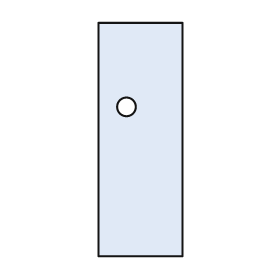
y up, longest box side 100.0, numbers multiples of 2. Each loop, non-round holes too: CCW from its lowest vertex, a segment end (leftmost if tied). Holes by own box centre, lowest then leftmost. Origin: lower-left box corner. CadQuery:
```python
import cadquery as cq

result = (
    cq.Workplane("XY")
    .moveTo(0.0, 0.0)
    .lineTo(36.0, 0.0)
    .lineTo(36.0, 100.0)
    .lineTo(0.0, 100.0)
    .close()
    .moveTo(12.0, 64.0)
    .circle(4.0)
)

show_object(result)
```